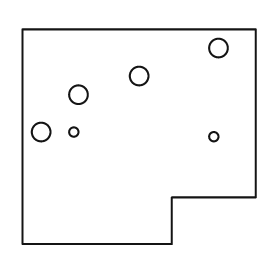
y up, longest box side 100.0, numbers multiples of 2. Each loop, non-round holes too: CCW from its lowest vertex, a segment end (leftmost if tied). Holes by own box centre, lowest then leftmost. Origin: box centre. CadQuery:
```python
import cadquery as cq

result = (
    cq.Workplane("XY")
    .moveTo(-50.0, -46.0)
    .lineTo(14.0, -46.0)
    .lineTo(14.0, -26.0)
    .lineTo(50.0, -26.0)
    .lineTo(50.0, 46.0)
    .lineTo(-50.0, 46.0)
    .close()
    .moveTo(32.0, 0.0)
    .circle(2.0)
    .moveTo(-42.0, 2.0)
    .circle(4.0)
    .moveTo(-28.0, 2.0)
    .circle(2.0)
    .moveTo(-26.0, 18.0)
    .circle(4.0)
    .moveTo(0.0, 26.0)
    .circle(4.0)
    .moveTo(34.0, 38.0)
    .circle(4.0)
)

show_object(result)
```